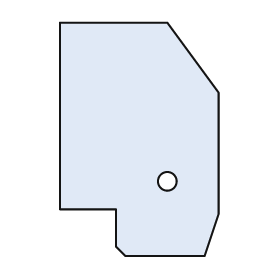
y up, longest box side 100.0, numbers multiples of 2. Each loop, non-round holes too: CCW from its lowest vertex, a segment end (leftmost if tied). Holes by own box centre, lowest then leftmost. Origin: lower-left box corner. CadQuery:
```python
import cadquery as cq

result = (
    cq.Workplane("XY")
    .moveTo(28.0, 0.0)
    .lineTo(62.0, 0.0)
    .lineTo(68.0, 18.0)
    .lineTo(68.0, 70.0)
    .lineTo(46.0, 100.0)
    .lineTo(0.0, 100.0)
    .lineTo(0.0, 20.0)
    .lineTo(24.0, 20.0)
    .lineTo(24.0, 4.0)
    .close()
    .moveTo(46.0, 32.0)
    .circle(4.0)
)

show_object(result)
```